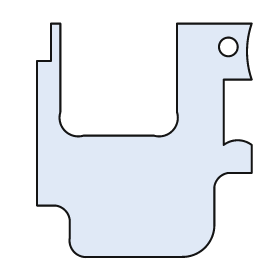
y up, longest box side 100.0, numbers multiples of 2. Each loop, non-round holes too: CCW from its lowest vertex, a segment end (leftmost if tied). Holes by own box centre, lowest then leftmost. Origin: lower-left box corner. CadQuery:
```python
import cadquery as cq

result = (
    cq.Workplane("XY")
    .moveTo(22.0, 0.0)
    .lineTo(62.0, 0.0)
    .threePointArc((72.0, 4.0), (76.0, 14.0))
    .lineTo(76.0, 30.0)
    .threePointArc((78.0, 34.0), (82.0, 36.0))
    .lineTo(92.0, 36.0)
    .lineTo(92.0, 48.0)
    .threePointArc((86.0, 50.0), (80.0, 48.0))
    .lineTo(80.0, 76.0)
    .lineTo(92.0, 76.0)
    .threePointArc((90.0, 88.0), (92.0, 100.0))
    .lineTo(60.0, 100.0)
    .lineTo(60.0, 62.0)
    .threePointArc((58.0, 54.0), (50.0, 52.0))
    .lineTo(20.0, 52.0)
    .threePointArc((12.0, 54.0), (10.0, 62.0))
    .lineTo(10.0, 100.0)
    .lineTo(6.0, 100.0)
    .lineTo(6.0, 84.0)
    .lineTo(0.0, 84.0)
    .lineTo(0.0, 22.0)
    .lineTo(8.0, 22.0)
    .threePointArc((12.0, 20.0), (14.0, 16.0))
    .lineTo(14.0, 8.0)
    .threePointArc((16.0, 2.0), (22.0, 0.0))
    .close()
    .moveTo(82.0, 90.0)
    .circle(4.0)
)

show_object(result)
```